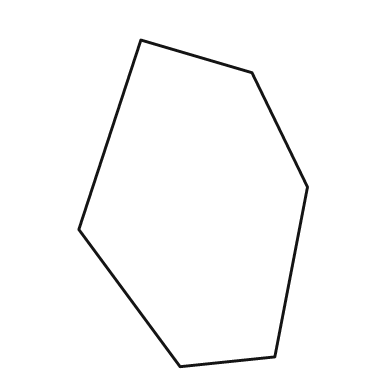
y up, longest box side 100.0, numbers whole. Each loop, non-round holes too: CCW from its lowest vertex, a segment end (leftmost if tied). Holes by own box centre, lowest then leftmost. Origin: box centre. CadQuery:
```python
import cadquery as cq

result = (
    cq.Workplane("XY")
    .moveTo(-4.0, -50.0)
    .lineTo(25.0, -47.0)
    .lineTo(35.0, 5.0)
    .lineTo(18.0, 40.0)
    .lineTo(-16.0, 50.0)
    .lineTo(-35.0, -8.0)
    .close()
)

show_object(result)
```